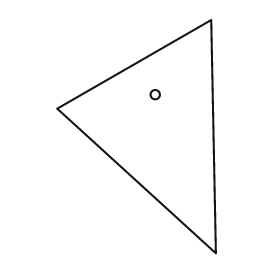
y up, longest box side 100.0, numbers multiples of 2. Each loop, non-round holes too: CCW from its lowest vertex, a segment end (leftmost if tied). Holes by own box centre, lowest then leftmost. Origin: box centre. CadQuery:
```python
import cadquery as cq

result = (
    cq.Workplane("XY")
    .moveTo(34.0, -50.0)
    .lineTo(32.0, 50.0)
    .lineTo(-34.0, 12.0)
    .close()
    .moveTo(8.0, 18.0)
    .circle(2.0)
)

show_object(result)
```